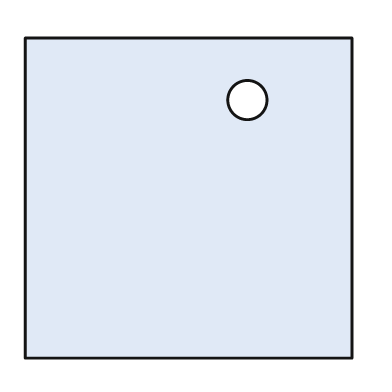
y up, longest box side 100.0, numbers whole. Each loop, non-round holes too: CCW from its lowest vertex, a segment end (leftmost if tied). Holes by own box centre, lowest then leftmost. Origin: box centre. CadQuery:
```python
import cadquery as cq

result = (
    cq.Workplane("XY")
    .moveTo(-50.0, -49.0)
    .lineTo(50.0, -49.0)
    .lineTo(50.0, 49.0)
    .lineTo(-50.0, 49.0)
    .close()
    .moveTo(18.0, 30.0)
    .circle(6.0)
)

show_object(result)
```